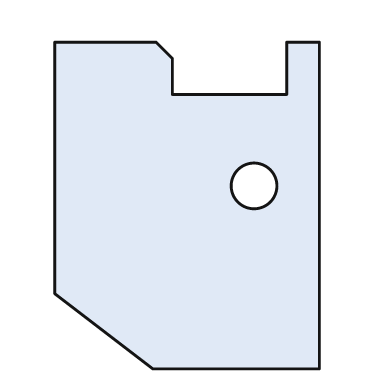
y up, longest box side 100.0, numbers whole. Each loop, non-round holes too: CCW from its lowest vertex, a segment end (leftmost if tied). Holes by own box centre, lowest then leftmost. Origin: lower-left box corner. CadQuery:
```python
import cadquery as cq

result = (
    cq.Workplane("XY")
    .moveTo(30.0, 0.0)
    .lineTo(81.0, 0.0)
    .lineTo(81.0, 100.0)
    .lineTo(71.0, 100.0)
    .lineTo(71.0, 84.0)
    .lineTo(36.0, 84.0)
    .lineTo(36.0, 95.0)
    .lineTo(31.0, 100.0)
    .lineTo(0.0, 100.0)
    .lineTo(0.0, 23.0)
    .close()
    .moveTo(61.0, 56.0)
    .circle(7.0)
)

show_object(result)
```